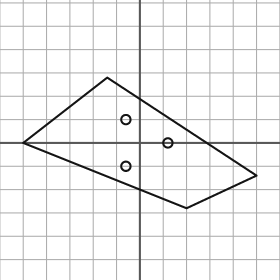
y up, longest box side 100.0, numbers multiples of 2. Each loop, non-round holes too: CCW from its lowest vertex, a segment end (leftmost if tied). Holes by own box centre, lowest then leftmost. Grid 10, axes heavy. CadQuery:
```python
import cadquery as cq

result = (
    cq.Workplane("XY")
    .moveTo(20.0, -28.0)
    .lineTo(50.0, -14.0)
    .lineTo(-14.0, 28.0)
    .lineTo(-50.0, 0.0)
    .close()
    .moveTo(-6.0, -10.0)
    .circle(2.0)
    .moveTo(12.0, 0.0)
    .circle(2.0)
    .moveTo(-6.0, 10.0)
    .circle(2.0)
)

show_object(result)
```